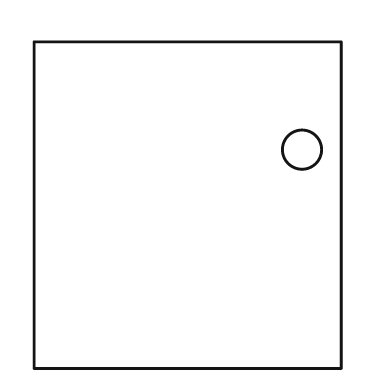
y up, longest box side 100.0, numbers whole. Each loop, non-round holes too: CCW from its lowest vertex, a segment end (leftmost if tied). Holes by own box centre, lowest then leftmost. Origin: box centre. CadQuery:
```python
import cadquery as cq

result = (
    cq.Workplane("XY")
    .moveTo(-47.0, -50.0)
    .lineTo(47.0, -50.0)
    .lineTo(47.0, 50.0)
    .lineTo(-47.0, 50.0)
    .close()
    .moveTo(35.0, 17.0)
    .circle(6.0)
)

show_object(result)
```